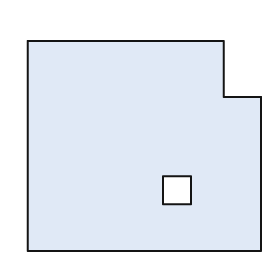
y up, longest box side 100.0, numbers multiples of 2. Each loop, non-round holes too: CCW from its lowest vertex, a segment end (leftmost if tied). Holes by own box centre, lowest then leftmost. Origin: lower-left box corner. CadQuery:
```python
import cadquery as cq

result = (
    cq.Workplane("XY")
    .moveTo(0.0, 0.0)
    .lineTo(100.0, 0.0)
    .lineTo(100.0, 66.0)
    .lineTo(84.0, 66.0)
    .lineTo(84.0, 90.0)
    .lineTo(0.0, 90.0)
    .close()
    .moveTo(58.0, 20.0)
    .lineTo(70.0, 20.0)
    .lineTo(70.0, 32.0)
    .lineTo(58.0, 32.0)
    .close()
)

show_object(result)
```